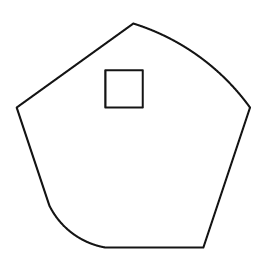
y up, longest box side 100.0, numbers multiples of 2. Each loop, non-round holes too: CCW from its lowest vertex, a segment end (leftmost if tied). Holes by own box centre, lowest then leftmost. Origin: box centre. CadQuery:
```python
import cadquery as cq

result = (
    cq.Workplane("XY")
    .moveTo(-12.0, -48.0)
    .lineTo(30.0, -48.0)
    .lineTo(50.0, 12.0)
    .threePointArc((28.0, 34.0), (0.0, 48.0))
    .lineTo(-50.0, 12.0)
    .lineTo(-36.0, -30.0)
    .threePointArc((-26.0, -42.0), (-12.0, -48.0))
    .close()
    .moveTo(-12.0, 12.0)
    .lineTo(4.0, 12.0)
    .lineTo(4.0, 28.0)
    .lineTo(-12.0, 28.0)
    .close()
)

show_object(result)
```